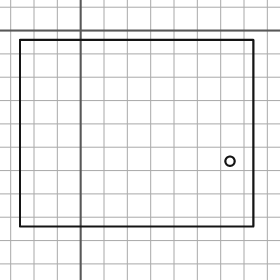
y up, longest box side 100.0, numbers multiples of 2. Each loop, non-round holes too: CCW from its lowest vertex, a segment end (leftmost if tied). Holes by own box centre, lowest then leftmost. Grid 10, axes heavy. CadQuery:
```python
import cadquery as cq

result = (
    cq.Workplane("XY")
    .moveTo(-26.0, -84.0)
    .lineTo(74.0, -84.0)
    .lineTo(74.0, -4.0)
    .lineTo(-26.0, -4.0)
    .close()
    .moveTo(64.0, -56.0)
    .circle(2.0)
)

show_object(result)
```